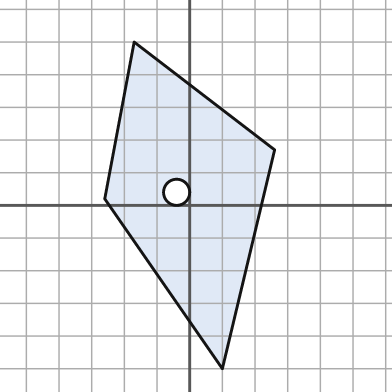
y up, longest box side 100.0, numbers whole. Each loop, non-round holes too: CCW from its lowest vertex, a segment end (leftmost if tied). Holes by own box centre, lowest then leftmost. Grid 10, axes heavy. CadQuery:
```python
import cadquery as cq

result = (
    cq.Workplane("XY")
    .moveTo(10.0, -50.0)
    .lineTo(26.0, 17.0)
    .lineTo(-17.0, 50.0)
    .lineTo(-26.0, 2.0)
    .close()
    .moveTo(-4.0, 4.0)
    .circle(4.0)
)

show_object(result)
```